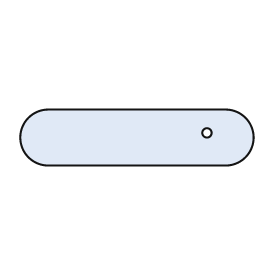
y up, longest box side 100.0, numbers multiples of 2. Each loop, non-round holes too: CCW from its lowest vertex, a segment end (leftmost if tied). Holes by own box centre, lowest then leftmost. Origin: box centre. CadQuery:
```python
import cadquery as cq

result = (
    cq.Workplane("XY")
    .moveTo(-38.0, -12.0)
    .lineTo(38.0, -12.0)
    .threePointArc((50.0, 0.0), (38.0, 12.0))
    .lineTo(-38.0, 12.0)
    .threePointArc((-50.0, 0.0), (-38.0, -12.0))
    .close()
    .moveTo(30.0, 2.0)
    .circle(2.0)
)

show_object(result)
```